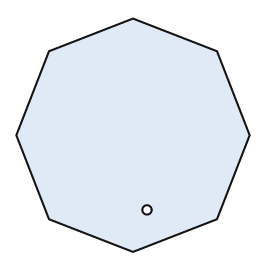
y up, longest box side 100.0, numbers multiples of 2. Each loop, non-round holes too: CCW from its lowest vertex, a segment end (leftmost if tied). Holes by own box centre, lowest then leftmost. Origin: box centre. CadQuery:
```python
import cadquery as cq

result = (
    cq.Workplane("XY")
    .moveTo(0.0, -50.0)
    .lineTo(36.0, -36.0)
    .lineTo(50.0, 0.0)
    .lineTo(36.0, 36.0)
    .lineTo(0.0, 50.0)
    .lineTo(-36.0, 36.0)
    .lineTo(-50.0, 0.0)
    .lineTo(-36.0, -36.0)
    .close()
    .moveTo(6.0, -32.0)
    .circle(2.0)
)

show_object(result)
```